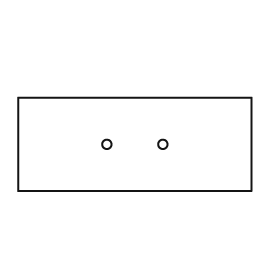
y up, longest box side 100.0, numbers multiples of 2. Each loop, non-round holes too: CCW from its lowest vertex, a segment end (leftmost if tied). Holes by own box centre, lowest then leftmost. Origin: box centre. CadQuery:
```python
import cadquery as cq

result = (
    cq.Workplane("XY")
    .moveTo(-50.0, -20.0)
    .lineTo(50.0, -20.0)
    .lineTo(50.0, 20.0)
    .lineTo(-50.0, 20.0)
    .close()
    .moveTo(-12.0, 0.0)
    .circle(2.0)
    .moveTo(12.0, 0.0)
    .circle(2.0)
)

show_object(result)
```